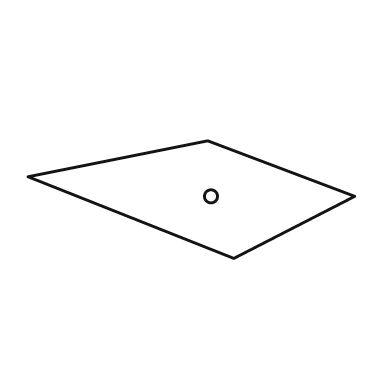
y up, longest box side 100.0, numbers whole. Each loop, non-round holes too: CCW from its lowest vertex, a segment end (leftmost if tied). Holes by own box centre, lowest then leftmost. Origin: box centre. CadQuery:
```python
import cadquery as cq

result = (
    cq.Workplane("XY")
    .moveTo(13.0, -18.0)
    .lineTo(50.0, 1.0)
    .lineTo(5.0, 18.0)
    .lineTo(-50.0, 7.0)
    .close()
    .moveTo(6.0, 1.0)
    .circle(2.0)
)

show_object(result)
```